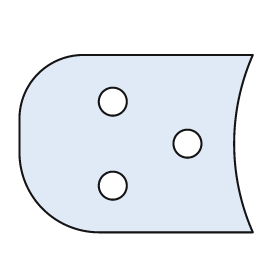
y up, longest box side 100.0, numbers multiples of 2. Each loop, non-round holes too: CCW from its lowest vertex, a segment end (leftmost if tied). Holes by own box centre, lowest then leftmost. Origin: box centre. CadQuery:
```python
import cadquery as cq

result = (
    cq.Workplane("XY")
    .moveTo(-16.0, -38.0)
    .lineTo(50.0, -38.0)
    .threePointArc((42.0, 0.0), (50.0, 38.0))
    .lineTo(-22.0, 38.0)
    .threePointArc((-42.0, 30.0), (-50.0, 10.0))
    .lineTo(-50.0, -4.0)
    .threePointArc((-40.0, -28.0), (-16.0, -38.0))
    .close()
    .moveTo(-10.0, -18.0)
    .circle(6.0)
    .moveTo(22.0, 0.0)
    .circle(6.0)
    .moveTo(-10.0, 18.0)
    .circle(6.0)
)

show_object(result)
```